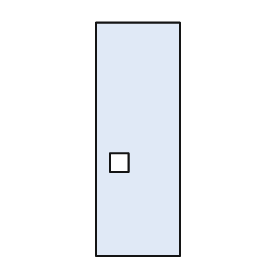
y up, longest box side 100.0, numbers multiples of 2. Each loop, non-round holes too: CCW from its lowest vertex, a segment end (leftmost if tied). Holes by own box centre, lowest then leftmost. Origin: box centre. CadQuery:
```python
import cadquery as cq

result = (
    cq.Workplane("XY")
    .moveTo(-18.0, -50.0)
    .lineTo(18.0, -50.0)
    .lineTo(18.0, 50.0)
    .lineTo(-18.0, 50.0)
    .close()
    .moveTo(-12.0, -14.0)
    .lineTo(-4.0, -14.0)
    .lineTo(-4.0, -6.0)
    .lineTo(-12.0, -6.0)
    .close()
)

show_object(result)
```